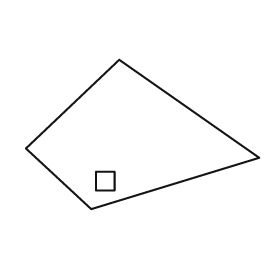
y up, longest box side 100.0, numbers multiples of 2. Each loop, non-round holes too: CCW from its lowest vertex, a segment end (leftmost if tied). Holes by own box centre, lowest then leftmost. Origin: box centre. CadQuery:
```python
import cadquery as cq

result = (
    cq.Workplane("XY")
    .moveTo(-22.0, -32.0)
    .lineTo(50.0, -10.0)
    .lineTo(-10.0, 32.0)
    .lineTo(-50.0, -6.0)
    .close()
    .moveTo(-20.0, -24.0)
    .lineTo(-12.0, -24.0)
    .lineTo(-12.0, -16.0)
    .lineTo(-20.0, -16.0)
    .close()
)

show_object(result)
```